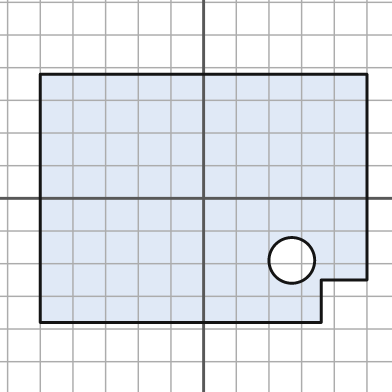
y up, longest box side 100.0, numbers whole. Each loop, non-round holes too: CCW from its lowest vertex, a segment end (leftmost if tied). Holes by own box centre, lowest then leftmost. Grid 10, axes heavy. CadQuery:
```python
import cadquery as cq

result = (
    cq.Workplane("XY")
    .moveTo(-50.0, -38.0)
    .lineTo(36.0, -38.0)
    .lineTo(36.0, -25.0)
    .lineTo(50.0, -25.0)
    .lineTo(50.0, 38.0)
    .lineTo(-50.0, 38.0)
    .close()
    .moveTo(27.0, -19.0)
    .circle(7.0)
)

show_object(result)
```